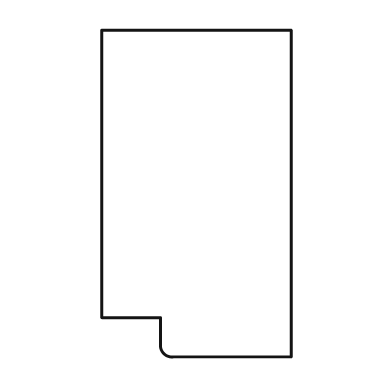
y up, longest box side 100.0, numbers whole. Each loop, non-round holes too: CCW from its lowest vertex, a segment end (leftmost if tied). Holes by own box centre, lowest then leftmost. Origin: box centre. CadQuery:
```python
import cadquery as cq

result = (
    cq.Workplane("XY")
    .moveTo(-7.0, -50.0)
    .lineTo(29.0, -50.0)
    .lineTo(29.0, 50.0)
    .lineTo(-29.0, 50.0)
    .lineTo(-29.0, -38.0)
    .lineTo(-11.0, -38.0)
    .lineTo(-11.0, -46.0)
    .threePointArc((-10.0, -49.0), (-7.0, -50.0))
    .close()
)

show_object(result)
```